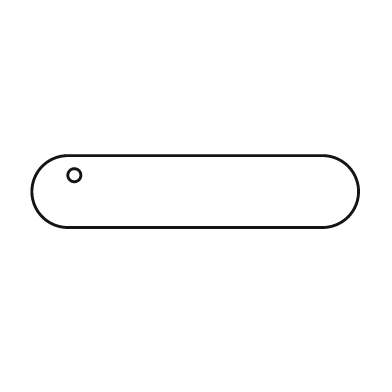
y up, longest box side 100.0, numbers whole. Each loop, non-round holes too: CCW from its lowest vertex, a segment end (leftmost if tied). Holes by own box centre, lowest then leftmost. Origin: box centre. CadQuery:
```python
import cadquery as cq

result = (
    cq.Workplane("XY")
    .moveTo(-39.0, -11.0)
    .lineTo(39.0, -11.0)
    .threePointArc((50.0, 0.0), (39.0, 11.0))
    .lineTo(-39.0, 11.0)
    .threePointArc((-50.0, 0.0), (-39.0, -11.0))
    .close()
    .moveTo(-37.0, 5.0)
    .circle(2.0)
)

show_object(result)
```